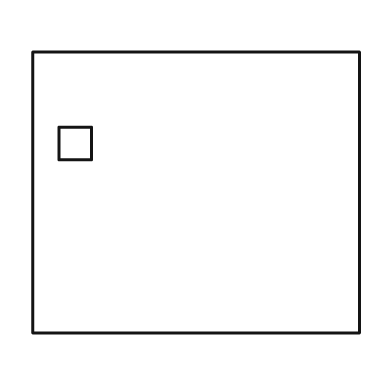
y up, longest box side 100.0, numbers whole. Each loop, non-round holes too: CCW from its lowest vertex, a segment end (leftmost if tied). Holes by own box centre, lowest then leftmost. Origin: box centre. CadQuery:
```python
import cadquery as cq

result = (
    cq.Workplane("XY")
    .moveTo(-50.0, -43.0)
    .lineTo(50.0, -43.0)
    .lineTo(50.0, 43.0)
    .lineTo(-50.0, 43.0)
    .close()
    .moveTo(-42.0, 10.0)
    .lineTo(-32.0, 10.0)
    .lineTo(-32.0, 20.0)
    .lineTo(-42.0, 20.0)
    .close()
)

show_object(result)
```